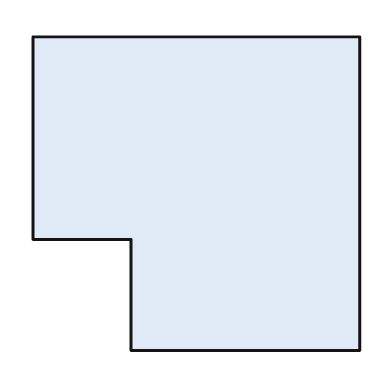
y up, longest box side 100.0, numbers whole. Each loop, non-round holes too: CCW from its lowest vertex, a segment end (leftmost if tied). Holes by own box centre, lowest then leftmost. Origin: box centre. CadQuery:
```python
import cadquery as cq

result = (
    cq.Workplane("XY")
    .moveTo(-20.0, -48.0)
    .lineTo(50.0, -48.0)
    .lineTo(50.0, 48.0)
    .lineTo(-50.0, 48.0)
    .lineTo(-50.0, -14.0)
    .lineTo(-20.0, -14.0)
    .close()
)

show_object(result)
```